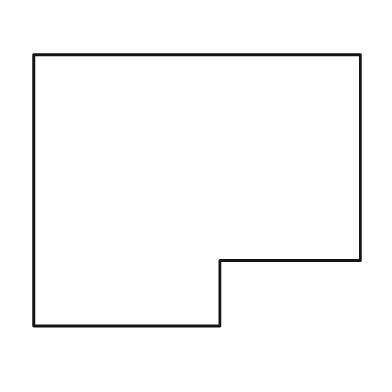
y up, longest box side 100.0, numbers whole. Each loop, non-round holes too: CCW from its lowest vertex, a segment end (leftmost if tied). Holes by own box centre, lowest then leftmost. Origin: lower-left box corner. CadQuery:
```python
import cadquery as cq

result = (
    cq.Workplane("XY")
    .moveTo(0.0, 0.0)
    .lineTo(57.0, 0.0)
    .lineTo(57.0, 20.0)
    .lineTo(100.0, 20.0)
    .lineTo(100.0, 83.0)
    .lineTo(0.0, 83.0)
    .close()
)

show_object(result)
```